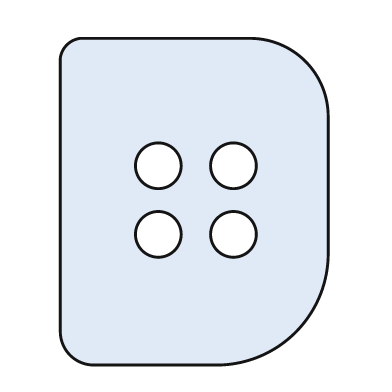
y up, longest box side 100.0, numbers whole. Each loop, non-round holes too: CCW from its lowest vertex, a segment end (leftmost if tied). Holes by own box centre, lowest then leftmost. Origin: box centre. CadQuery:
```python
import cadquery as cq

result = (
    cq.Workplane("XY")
    .moveTo(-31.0, -50.0)
    .lineTo(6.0, -50.0)
    .threePointArc((31.0, -40.0), (41.0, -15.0))
    .lineTo(41.0, 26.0)
    .threePointArc((34.0, 43.0), (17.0, 50.0))
    .lineTo(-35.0, 50.0)
    .threePointArc((-39.0, 48.0), (-41.0, 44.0))
    .lineTo(-41.0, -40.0)
    .threePointArc((-38.0, -47.0), (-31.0, -50.0))
    .close()
    .moveTo(-11.0, -10.0)
    .circle(7.0)
    .moveTo(12.0, -10.0)
    .circle(7.0)
    .moveTo(-11.0, 11.0)
    .circle(7.0)
    .moveTo(12.0, 11.0)
    .circle(7.0)
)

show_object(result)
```